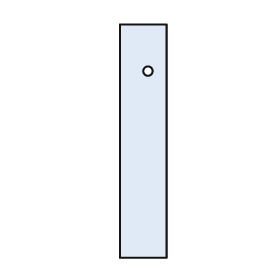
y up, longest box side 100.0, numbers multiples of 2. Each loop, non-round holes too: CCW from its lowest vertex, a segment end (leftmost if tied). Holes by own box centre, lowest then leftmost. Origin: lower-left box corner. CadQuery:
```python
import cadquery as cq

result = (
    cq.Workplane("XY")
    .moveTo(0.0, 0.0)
    .lineTo(20.0, 0.0)
    .lineTo(20.0, 100.0)
    .lineTo(0.0, 100.0)
    .close()
    .moveTo(12.0, 80.0)
    .circle(2.0)
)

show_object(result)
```